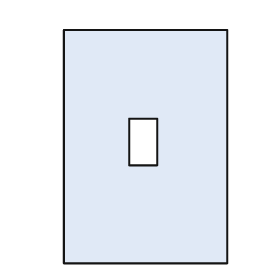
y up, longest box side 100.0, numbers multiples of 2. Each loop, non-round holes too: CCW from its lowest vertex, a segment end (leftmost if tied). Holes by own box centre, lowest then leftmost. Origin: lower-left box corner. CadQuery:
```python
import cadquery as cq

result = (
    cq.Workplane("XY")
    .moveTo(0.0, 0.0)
    .lineTo(70.0, 0.0)
    .lineTo(70.0, 100.0)
    .lineTo(0.0, 100.0)
    .close()
    .moveTo(28.0, 42.0)
    .lineTo(40.0, 42.0)
    .lineTo(40.0, 62.0)
    .lineTo(28.0, 62.0)
    .close()
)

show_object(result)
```